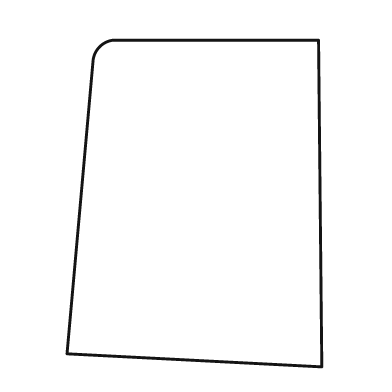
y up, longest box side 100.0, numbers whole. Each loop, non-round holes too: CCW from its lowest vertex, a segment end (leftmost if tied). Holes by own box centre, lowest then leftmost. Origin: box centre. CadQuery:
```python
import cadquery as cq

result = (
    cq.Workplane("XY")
    .moveTo(39.0, -50.0)
    .lineTo(38.0, 50.0)
    .lineTo(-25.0, 50.0)
    .threePointArc((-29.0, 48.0), (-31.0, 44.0))
    .lineTo(-39.0, -46.0)
    .close()
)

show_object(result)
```